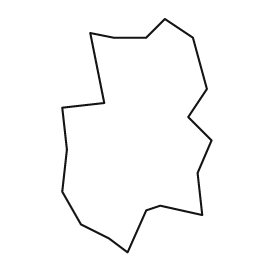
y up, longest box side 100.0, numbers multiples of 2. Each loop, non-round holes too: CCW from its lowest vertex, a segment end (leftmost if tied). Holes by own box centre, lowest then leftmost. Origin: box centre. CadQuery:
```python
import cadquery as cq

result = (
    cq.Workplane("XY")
    .moveTo(-4.0, -50.0)
    .lineTo(4.0, -32.0)
    .lineTo(10.0, -30.0)
    .lineTo(28.0, -34.0)
    .lineTo(26.0, -16.0)
    .lineTo(32.0, -2.0)
    .lineTo(22.0, 8.0)
    .lineTo(30.0, 20.0)
    .lineTo(24.0, 42.0)
    .lineTo(12.0, 50.0)
    .lineTo(4.0, 42.0)
    .lineTo(-10.0, 42.0)
    .lineTo(-20.0, 44.0)
    .lineTo(-14.0, 14.0)
    .lineTo(-32.0, 12.0)
    .lineTo(-30.0, -6.0)
    .lineTo(-32.0, -24.0)
    .lineTo(-24.0, -38.0)
    .lineTo(-12.0, -44.0)
    .close()
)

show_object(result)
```